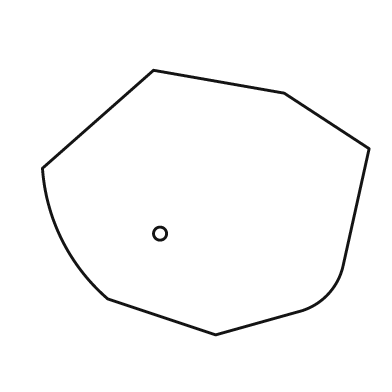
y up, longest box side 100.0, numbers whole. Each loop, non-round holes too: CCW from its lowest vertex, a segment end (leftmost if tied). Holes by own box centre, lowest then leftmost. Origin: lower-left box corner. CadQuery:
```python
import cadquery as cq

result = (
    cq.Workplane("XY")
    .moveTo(53.0, 0.0)
    .lineTo(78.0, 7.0)
    .threePointArc((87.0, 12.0), (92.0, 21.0))
    .lineTo(100.0, 57.0)
    .lineTo(74.0, 74.0)
    .lineTo(34.0, 81.0)
    .lineTo(0.0, 51.0)
    .threePointArc((6.0, 29.0), (20.0, 11.0))
    .close()
    .moveTo(36.0, 31.0)
    .circle(2.0)
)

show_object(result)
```